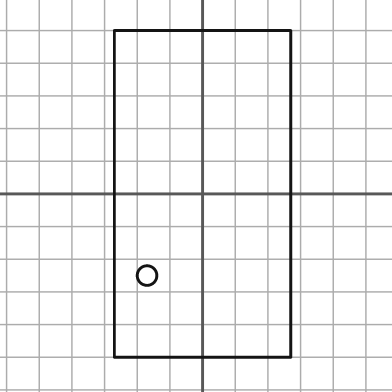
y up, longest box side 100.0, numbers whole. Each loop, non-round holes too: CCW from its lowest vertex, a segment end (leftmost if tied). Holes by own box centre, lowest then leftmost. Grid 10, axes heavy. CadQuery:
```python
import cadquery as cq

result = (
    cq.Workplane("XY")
    .moveTo(-27.0, -50.0)
    .lineTo(27.0, -50.0)
    .lineTo(27.0, 50.0)
    .lineTo(-27.0, 50.0)
    .close()
    .moveTo(-17.0, -25.0)
    .circle(3.0)
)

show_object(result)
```